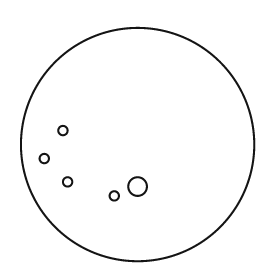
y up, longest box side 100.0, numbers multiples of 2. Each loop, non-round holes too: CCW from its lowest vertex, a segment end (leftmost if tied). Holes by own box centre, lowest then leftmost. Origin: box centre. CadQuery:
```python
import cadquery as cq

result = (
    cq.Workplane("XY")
    .moveTo(0.0, 0.0)
    .circle(50.0)
    .moveTo(-10.0, -22.0)
    .circle(2.0)
    .moveTo(0.0, -18.0)
    .circle(4.0)
    .moveTo(-30.0, -16.0)
    .circle(2.0)
    .moveTo(-40.0, -6.0)
    .circle(2.0)
    .moveTo(-32.0, 6.0)
    .circle(2.0)
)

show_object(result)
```